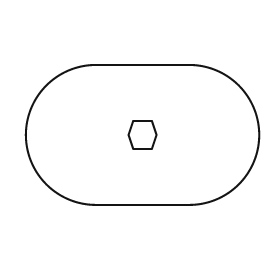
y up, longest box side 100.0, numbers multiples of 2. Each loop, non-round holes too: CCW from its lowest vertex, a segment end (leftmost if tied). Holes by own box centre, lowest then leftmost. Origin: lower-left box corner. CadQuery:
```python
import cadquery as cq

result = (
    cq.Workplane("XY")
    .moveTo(30.0, 0.0)
    .lineTo(70.0, 0.0)
    .threePointArc((100.0, 30.0), (70.0, 60.0))
    .lineTo(30.0, 60.0)
    .threePointArc((0.0, 30.0), (30.0, 0.0))
    .close()
    .moveTo(46.0, 24.0)
    .lineTo(54.0, 24.0)
    .lineTo(56.0, 30.0)
    .lineTo(54.0, 36.0)
    .lineTo(46.0, 36.0)
    .lineTo(44.0, 30.0)
    .close()
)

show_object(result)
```